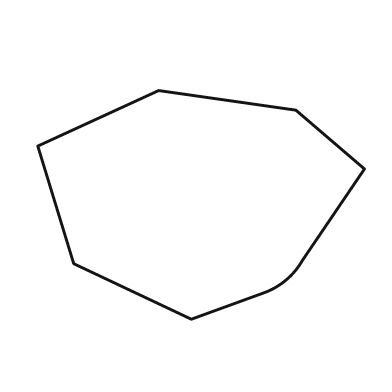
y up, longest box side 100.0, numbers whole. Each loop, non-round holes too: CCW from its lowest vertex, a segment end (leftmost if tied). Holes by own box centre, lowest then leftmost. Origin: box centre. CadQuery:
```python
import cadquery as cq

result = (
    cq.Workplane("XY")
    .moveTo(-3.0, -35.0)
    .lineTo(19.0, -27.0)
    .threePointArc((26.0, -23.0), (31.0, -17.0))
    .lineTo(50.0, 11.0)
    .lineTo(29.0, 29.0)
    .lineTo(-13.0, 35.0)
    .lineTo(-50.0, 18.0)
    .lineTo(-39.0, -18.0)
    .close()
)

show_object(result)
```